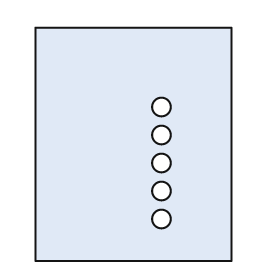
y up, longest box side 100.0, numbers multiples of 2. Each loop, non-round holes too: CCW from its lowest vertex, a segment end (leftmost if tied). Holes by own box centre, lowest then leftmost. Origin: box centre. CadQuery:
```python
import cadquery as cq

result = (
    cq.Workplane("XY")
    .moveTo(-42.0, -50.0)
    .lineTo(42.0, -50.0)
    .lineTo(42.0, 50.0)
    .lineTo(-42.0, 50.0)
    .close()
    .moveTo(12.0, -32.0)
    .circle(4.0)
    .moveTo(12.0, -20.0)
    .circle(4.0)
    .moveTo(12.0, -8.0)
    .circle(4.0)
    .moveTo(12.0, 4.0)
    .circle(4.0)
    .moveTo(12.0, 16.0)
    .circle(4.0)
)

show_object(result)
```